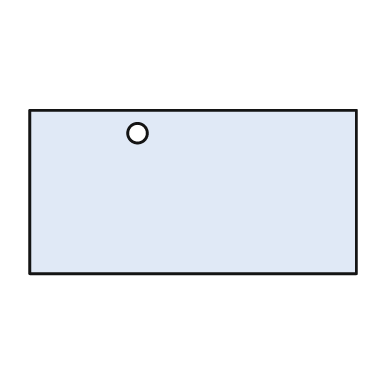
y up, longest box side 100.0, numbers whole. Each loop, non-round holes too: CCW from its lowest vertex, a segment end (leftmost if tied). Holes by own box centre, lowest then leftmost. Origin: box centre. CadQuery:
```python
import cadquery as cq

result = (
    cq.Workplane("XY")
    .moveTo(-50.0, -25.0)
    .lineTo(50.0, -25.0)
    .lineTo(50.0, 25.0)
    .lineTo(-50.0, 25.0)
    .close()
    .moveTo(-17.0, 18.0)
    .circle(3.0)
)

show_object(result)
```